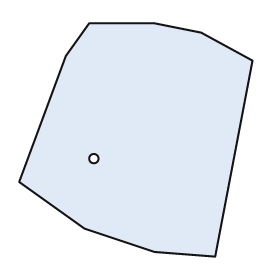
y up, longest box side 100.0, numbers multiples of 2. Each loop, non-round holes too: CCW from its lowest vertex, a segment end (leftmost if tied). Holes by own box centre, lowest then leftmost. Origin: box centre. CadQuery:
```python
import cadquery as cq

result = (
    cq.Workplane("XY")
    .moveTo(34.0, -50.0)
    .lineTo(50.0, 34.0)
    .lineTo(28.0, 46.0)
    .lineTo(8.0, 50.0)
    .lineTo(-20.0, 50.0)
    .lineTo(-30.0, 36.0)
    .lineTo(-50.0, -18.0)
    .lineTo(-22.0, -38.0)
    .lineTo(8.0, -48.0)
    .close()
    .moveTo(-18.0, -8.0)
    .circle(2.0)
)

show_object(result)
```